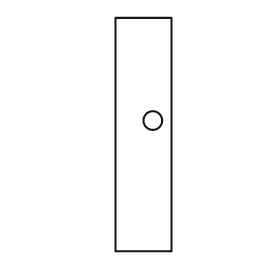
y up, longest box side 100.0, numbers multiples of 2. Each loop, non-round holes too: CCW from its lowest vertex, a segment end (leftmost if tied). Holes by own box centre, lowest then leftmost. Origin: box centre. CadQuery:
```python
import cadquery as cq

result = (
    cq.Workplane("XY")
    .moveTo(-12.0, -50.0)
    .lineTo(12.0, -50.0)
    .lineTo(12.0, 50.0)
    .lineTo(-12.0, 50.0)
    .close()
    .moveTo(4.0, 6.0)
    .circle(4.0)
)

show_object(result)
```